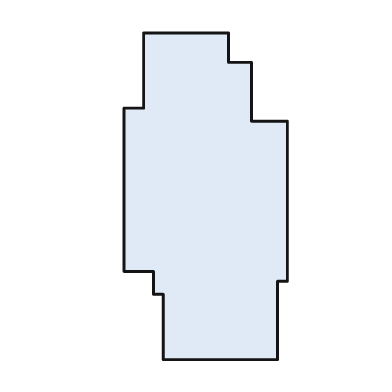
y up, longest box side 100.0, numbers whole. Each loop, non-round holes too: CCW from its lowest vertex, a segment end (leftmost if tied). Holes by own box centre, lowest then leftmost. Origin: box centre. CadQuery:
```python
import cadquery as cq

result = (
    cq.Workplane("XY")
    .moveTo(-13.0, -50.0)
    .lineTo(22.0, -50.0)
    .lineTo(22.0, -26.0)
    .lineTo(25.0, -26.0)
    .lineTo(25.0, 23.0)
    .lineTo(14.0, 23.0)
    .lineTo(14.0, 41.0)
    .lineTo(7.0, 41.0)
    .lineTo(7.0, 50.0)
    .lineTo(-19.0, 50.0)
    .lineTo(-19.0, 27.0)
    .lineTo(-25.0, 27.0)
    .lineTo(-25.0, -23.0)
    .lineTo(-16.0, -23.0)
    .lineTo(-16.0, -30.0)
    .lineTo(-13.0, -30.0)
    .close()
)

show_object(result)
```